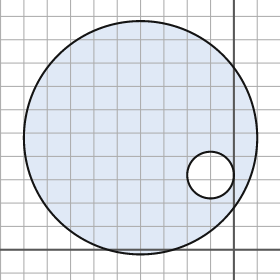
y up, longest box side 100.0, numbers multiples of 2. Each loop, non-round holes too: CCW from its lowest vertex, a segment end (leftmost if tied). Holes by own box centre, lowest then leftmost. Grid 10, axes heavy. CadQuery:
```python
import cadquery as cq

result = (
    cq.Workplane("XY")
    .moveTo(-40.0, 48.0)
    .circle(50.0)
    .moveTo(-10.0, 32.0)
    .circle(10.0)
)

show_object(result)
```